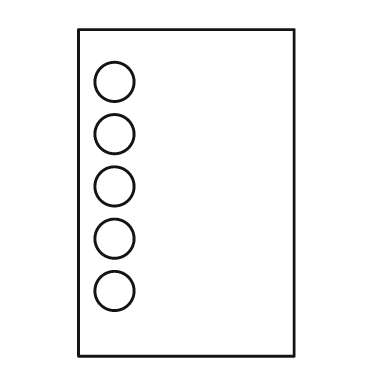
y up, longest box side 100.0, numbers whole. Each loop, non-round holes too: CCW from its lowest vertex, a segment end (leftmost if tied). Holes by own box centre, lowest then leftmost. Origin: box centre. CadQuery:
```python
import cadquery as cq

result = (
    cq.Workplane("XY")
    .moveTo(-33.0, -50.0)
    .lineTo(33.0, -50.0)
    .lineTo(33.0, 50.0)
    .lineTo(-33.0, 50.0)
    .close()
    .moveTo(-22.0, -30.0)
    .circle(6.0)
    .moveTo(-22.0, -14.0)
    .circle(6.0)
    .moveTo(-22.0, 2.0)
    .circle(6.0)
    .moveTo(-22.0, 18.0)
    .circle(6.0)
    .moveTo(-22.0, 34.0)
    .circle(6.0)
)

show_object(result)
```